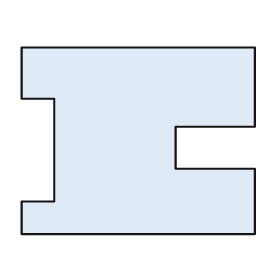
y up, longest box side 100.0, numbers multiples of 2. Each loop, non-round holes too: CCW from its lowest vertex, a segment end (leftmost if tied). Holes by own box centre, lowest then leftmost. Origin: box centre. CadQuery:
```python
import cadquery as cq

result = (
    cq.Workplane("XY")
    .moveTo(-50.0, -40.0)
    .lineTo(50.0, -40.0)
    .lineTo(50.0, -12.0)
    .lineTo(16.0, -12.0)
    .lineTo(16.0, 6.0)
    .lineTo(50.0, 6.0)
    .lineTo(50.0, 40.0)
    .lineTo(-50.0, 40.0)
    .lineTo(-50.0, 18.0)
    .lineTo(-36.0, 18.0)
    .lineTo(-36.0, -26.0)
    .lineTo(-50.0, -26.0)
    .close()
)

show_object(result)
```